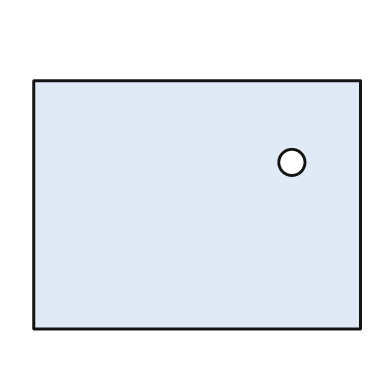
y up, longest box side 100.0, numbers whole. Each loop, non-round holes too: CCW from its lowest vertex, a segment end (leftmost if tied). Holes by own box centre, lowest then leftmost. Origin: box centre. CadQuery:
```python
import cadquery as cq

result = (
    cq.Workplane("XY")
    .moveTo(-50.0, -38.0)
    .lineTo(50.0, -38.0)
    .lineTo(50.0, 38.0)
    .lineTo(-50.0, 38.0)
    .close()
    .moveTo(29.0, 13.0)
    .circle(4.0)
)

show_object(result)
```